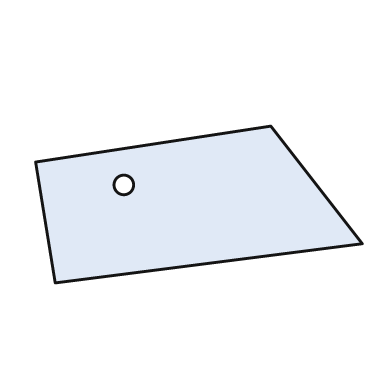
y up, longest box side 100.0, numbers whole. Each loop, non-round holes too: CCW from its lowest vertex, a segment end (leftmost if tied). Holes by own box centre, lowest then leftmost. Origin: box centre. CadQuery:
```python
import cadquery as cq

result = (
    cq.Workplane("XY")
    .moveTo(-44.0, -24.0)
    .lineTo(50.0, -12.0)
    .lineTo(22.0, 24.0)
    .lineTo(-50.0, 13.0)
    .close()
    .moveTo(-23.0, 6.0)
    .circle(3.0)
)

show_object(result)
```